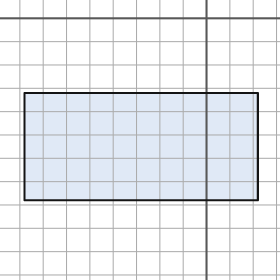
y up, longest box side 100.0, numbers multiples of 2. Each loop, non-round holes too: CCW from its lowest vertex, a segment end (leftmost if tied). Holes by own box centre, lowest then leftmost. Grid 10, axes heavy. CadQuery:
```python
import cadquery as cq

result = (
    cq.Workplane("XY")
    .moveTo(-78.0, -78.0)
    .lineTo(22.0, -78.0)
    .lineTo(22.0, -32.0)
    .lineTo(-78.0, -32.0)
    .close()
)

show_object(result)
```